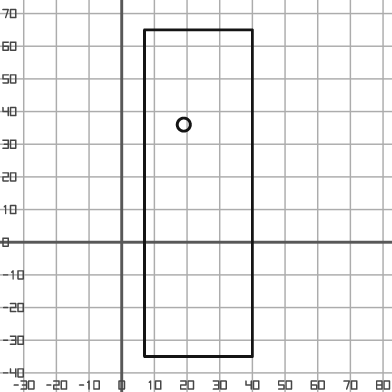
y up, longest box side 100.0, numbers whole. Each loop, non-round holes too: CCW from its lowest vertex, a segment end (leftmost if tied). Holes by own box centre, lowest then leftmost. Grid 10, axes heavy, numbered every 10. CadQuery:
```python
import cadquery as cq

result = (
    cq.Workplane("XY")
    .moveTo(7.0, -35.0)
    .lineTo(40.0, -35.0)
    .lineTo(40.0, 65.0)
    .lineTo(7.0, 65.0)
    .close()
    .moveTo(19.0, 36.0)
    .circle(2.0)
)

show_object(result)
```